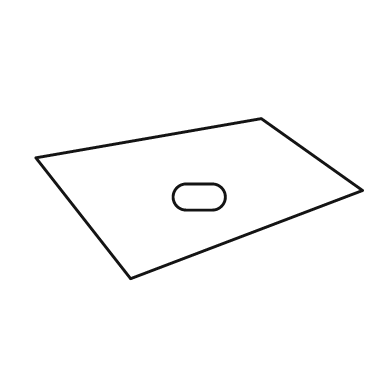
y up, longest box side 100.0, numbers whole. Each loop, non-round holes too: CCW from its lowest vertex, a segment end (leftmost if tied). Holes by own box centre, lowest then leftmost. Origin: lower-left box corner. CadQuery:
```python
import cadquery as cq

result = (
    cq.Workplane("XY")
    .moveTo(29.0, 0.0)
    .lineTo(100.0, 27.0)
    .lineTo(69.0, 49.0)
    .lineTo(0.0, 37.0)
    .close()
    .moveTo(46.0, 21.0)
    .lineTo(54.0, 21.0)
    .threePointArc((58.0, 25.0), (54.0, 29.0))
    .lineTo(46.0, 29.0)
    .threePointArc((42.0, 25.0), (46.0, 21.0))
    .close()
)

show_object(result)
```